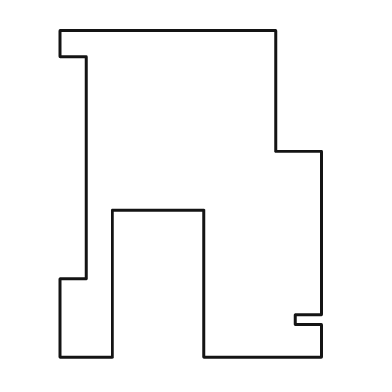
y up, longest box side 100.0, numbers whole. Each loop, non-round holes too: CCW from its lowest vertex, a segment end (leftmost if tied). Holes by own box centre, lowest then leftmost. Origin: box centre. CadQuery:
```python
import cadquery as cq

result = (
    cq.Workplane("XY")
    .moveTo(-40.0, -50.0)
    .lineTo(-24.0, -50.0)
    .lineTo(-24.0, -5.0)
    .lineTo(4.0, -5.0)
    .lineTo(4.0, -50.0)
    .lineTo(40.0, -50.0)
    .lineTo(40.0, -40.0)
    .lineTo(32.0, -40.0)
    .lineTo(32.0, -37.0)
    .lineTo(40.0, -37.0)
    .lineTo(40.0, 13.0)
    .lineTo(26.0, 13.0)
    .lineTo(26.0, 50.0)
    .lineTo(-40.0, 50.0)
    .lineTo(-40.0, 42.0)
    .lineTo(-32.0, 42.0)
    .lineTo(-32.0, -26.0)
    .lineTo(-40.0, -26.0)
    .close()
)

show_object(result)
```